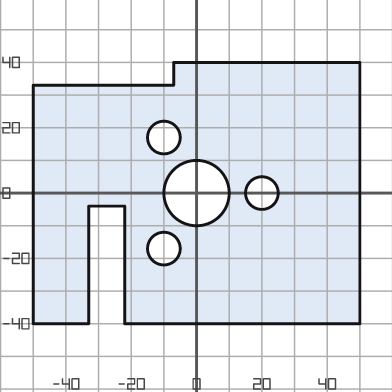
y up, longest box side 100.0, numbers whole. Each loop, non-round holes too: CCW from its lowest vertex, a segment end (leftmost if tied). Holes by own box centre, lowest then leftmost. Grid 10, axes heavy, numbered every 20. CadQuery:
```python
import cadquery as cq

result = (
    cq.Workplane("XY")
    .moveTo(-50.0, -40.0)
    .lineTo(-33.0, -40.0)
    .lineTo(-33.0, -4.0)
    .lineTo(-22.0, -4.0)
    .lineTo(-22.0, -40.0)
    .lineTo(50.0, -40.0)
    .lineTo(50.0, 40.0)
    .lineTo(-7.0, 40.0)
    .lineTo(-7.0, 33.0)
    .lineTo(-50.0, 33.0)
    .close()
    .moveTo(-10.0, -17.0)
    .circle(5.0)
    .moveTo(0.0, 0.0)
    .circle(10.0)
    .moveTo(20.0, 0.0)
    .circle(5.0)
    .moveTo(-10.0, 17.0)
    .circle(5.0)
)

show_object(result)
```